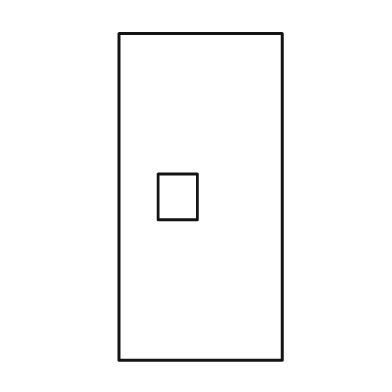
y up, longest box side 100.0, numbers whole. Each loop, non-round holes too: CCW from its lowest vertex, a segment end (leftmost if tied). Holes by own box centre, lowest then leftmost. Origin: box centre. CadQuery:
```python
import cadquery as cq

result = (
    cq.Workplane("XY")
    .moveTo(-25.0, -50.0)
    .lineTo(25.0, -50.0)
    .lineTo(25.0, 50.0)
    .lineTo(-25.0, 50.0)
    .close()
    .moveTo(-13.0, -7.0)
    .lineTo(-1.0, -7.0)
    .lineTo(-1.0, 7.0)
    .lineTo(-13.0, 7.0)
    .close()
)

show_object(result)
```